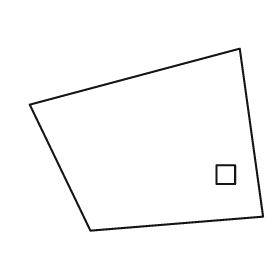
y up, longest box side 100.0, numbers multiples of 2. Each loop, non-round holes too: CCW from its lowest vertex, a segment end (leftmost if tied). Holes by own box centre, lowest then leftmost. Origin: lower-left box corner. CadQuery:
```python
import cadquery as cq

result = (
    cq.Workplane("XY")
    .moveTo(26.0, 0.0)
    .lineTo(100.0, 6.0)
    .lineTo(90.0, 78.0)
    .lineTo(0.0, 54.0)
    .close()
    .moveTo(80.0, 20.0)
    .lineTo(88.0, 20.0)
    .lineTo(88.0, 28.0)
    .lineTo(80.0, 28.0)
    .close()
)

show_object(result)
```